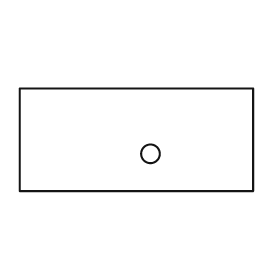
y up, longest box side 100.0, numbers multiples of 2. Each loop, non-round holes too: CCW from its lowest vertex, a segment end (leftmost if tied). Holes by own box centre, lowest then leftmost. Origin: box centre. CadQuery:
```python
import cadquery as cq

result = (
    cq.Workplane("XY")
    .moveTo(-50.0, -22.0)
    .lineTo(50.0, -22.0)
    .lineTo(50.0, 22.0)
    .lineTo(-50.0, 22.0)
    .close()
    .moveTo(6.0, -6.0)
    .circle(4.0)
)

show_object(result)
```